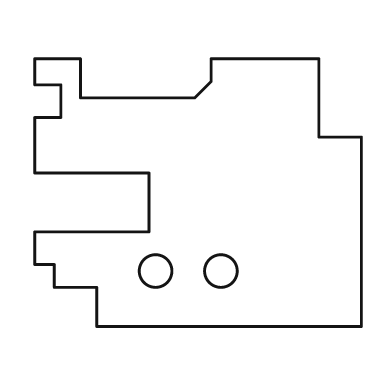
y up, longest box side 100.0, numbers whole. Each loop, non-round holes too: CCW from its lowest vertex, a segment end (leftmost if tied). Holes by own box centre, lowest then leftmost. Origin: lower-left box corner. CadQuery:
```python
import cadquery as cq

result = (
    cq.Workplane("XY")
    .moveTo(19.0, 0.0)
    .lineTo(100.0, 0.0)
    .lineTo(100.0, 58.0)
    .lineTo(87.0, 58.0)
    .lineTo(87.0, 82.0)
    .lineTo(54.0, 82.0)
    .lineTo(54.0, 75.0)
    .lineTo(49.0, 70.0)
    .lineTo(14.0, 70.0)
    .lineTo(14.0, 82.0)
    .lineTo(0.0, 82.0)
    .lineTo(0.0, 74.0)
    .lineTo(8.0, 74.0)
    .lineTo(8.0, 64.0)
    .lineTo(0.0, 64.0)
    .lineTo(0.0, 47.0)
    .lineTo(35.0, 47.0)
    .lineTo(35.0, 29.0)
    .lineTo(0.0, 29.0)
    .lineTo(0.0, 19.0)
    .lineTo(6.0, 19.0)
    .lineTo(6.0, 12.0)
    .lineTo(19.0, 12.0)
    .close()
    .moveTo(37.0, 17.0)
    .circle(5.0)
    .moveTo(57.0, 17.0)
    .circle(5.0)
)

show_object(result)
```